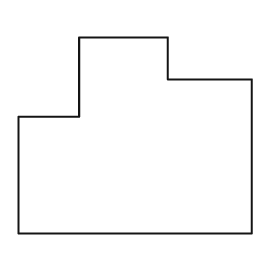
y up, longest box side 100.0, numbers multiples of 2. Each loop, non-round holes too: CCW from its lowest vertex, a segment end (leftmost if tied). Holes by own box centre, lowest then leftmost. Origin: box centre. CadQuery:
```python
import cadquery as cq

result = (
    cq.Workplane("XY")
    .moveTo(-50.0, -42.0)
    .lineTo(50.0, -42.0)
    .lineTo(50.0, 24.0)
    .lineTo(14.0, 24.0)
    .lineTo(14.0, 42.0)
    .lineTo(-24.0, 42.0)
    .lineTo(-24.0, 8.0)
    .lineTo(-50.0, 8.0)
    .close()
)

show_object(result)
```